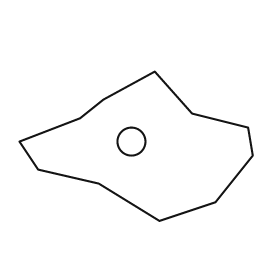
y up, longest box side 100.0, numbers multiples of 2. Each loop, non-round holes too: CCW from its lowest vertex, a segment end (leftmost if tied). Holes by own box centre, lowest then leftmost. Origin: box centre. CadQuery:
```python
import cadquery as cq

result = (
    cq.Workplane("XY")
    .moveTo(10.0, -32.0)
    .lineTo(34.0, -24.0)
    .lineTo(50.0, -4.0)
    .lineTo(48.0, 8.0)
    .lineTo(24.0, 14.0)
    .lineTo(8.0, 32.0)
    .lineTo(-14.0, 20.0)
    .lineTo(-24.0, 12.0)
    .lineTo(-50.0, 2.0)
    .lineTo(-42.0, -10.0)
    .lineTo(-16.0, -16.0)
    .close()
    .moveTo(-2.0, 2.0)
    .circle(6.0)
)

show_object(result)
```